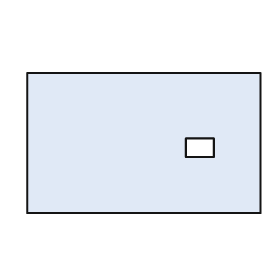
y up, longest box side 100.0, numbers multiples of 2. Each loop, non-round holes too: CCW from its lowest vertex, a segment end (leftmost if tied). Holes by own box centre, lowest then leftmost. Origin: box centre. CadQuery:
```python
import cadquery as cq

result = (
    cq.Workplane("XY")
    .moveTo(-50.0, -30.0)
    .lineTo(50.0, -30.0)
    .lineTo(50.0, 30.0)
    .lineTo(-50.0, 30.0)
    .close()
    .moveTo(18.0, -6.0)
    .lineTo(30.0, -6.0)
    .lineTo(30.0, 2.0)
    .lineTo(18.0, 2.0)
    .close()
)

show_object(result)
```